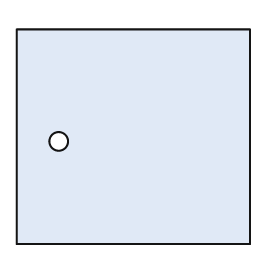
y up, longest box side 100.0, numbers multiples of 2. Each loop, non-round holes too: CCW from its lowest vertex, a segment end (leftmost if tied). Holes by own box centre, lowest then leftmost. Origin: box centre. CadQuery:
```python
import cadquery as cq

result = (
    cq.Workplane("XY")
    .moveTo(-50.0, -46.0)
    .lineTo(50.0, -46.0)
    .lineTo(50.0, 46.0)
    .lineTo(-50.0, 46.0)
    .close()
    .moveTo(-32.0, -2.0)
    .circle(4.0)
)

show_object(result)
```